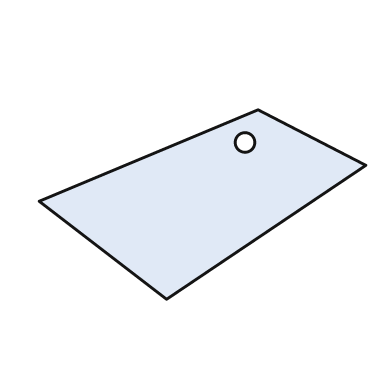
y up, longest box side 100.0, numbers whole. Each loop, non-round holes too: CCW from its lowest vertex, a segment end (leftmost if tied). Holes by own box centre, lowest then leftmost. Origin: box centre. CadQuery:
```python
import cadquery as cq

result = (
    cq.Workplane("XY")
    .moveTo(-11.0, -29.0)
    .lineTo(50.0, 12.0)
    .lineTo(17.0, 29.0)
    .lineTo(-50.0, 1.0)
    .close()
    .moveTo(13.0, 19.0)
    .circle(3.0)
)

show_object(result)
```